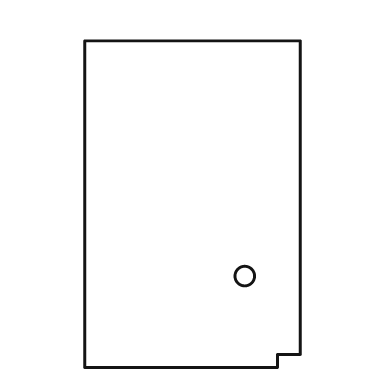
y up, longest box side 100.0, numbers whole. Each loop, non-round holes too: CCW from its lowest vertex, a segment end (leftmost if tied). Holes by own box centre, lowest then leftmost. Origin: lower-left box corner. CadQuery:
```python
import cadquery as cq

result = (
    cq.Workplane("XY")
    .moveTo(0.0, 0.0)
    .lineTo(59.0, 0.0)
    .lineTo(59.0, 4.0)
    .lineTo(66.0, 4.0)
    .lineTo(66.0, 100.0)
    .lineTo(0.0, 100.0)
    .close()
    .moveTo(49.0, 28.0)
    .circle(3.0)
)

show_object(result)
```